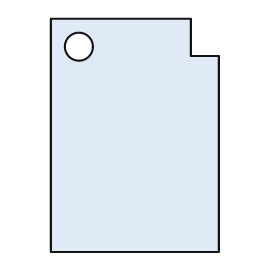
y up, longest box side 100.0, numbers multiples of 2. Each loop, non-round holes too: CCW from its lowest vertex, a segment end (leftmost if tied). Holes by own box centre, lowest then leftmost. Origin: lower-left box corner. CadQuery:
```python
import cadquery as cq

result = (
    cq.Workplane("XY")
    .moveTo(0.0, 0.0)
    .lineTo(72.0, 0.0)
    .lineTo(72.0, 84.0)
    .lineTo(60.0, 84.0)
    .lineTo(60.0, 100.0)
    .lineTo(0.0, 100.0)
    .close()
    .moveTo(12.0, 88.0)
    .circle(6.0)
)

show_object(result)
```